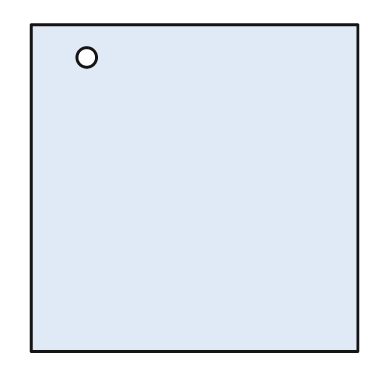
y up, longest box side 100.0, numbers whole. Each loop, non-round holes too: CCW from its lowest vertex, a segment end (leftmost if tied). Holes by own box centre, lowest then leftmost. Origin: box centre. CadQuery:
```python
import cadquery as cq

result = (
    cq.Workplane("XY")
    .moveTo(-50.0, -50.0)
    .lineTo(50.0, -50.0)
    .lineTo(50.0, 50.0)
    .lineTo(-50.0, 50.0)
    .close()
    .moveTo(-33.0, 40.0)
    .circle(3.0)
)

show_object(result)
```